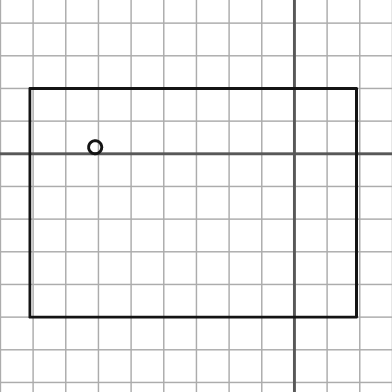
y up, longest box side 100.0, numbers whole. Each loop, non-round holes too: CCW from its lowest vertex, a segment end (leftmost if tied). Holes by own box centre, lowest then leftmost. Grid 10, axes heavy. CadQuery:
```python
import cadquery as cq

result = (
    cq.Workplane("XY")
    .moveTo(-81.0, -50.0)
    .lineTo(19.0, -50.0)
    .lineTo(19.0, 20.0)
    .lineTo(-81.0, 20.0)
    .close()
    .moveTo(-61.0, 2.0)
    .circle(2.0)
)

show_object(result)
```